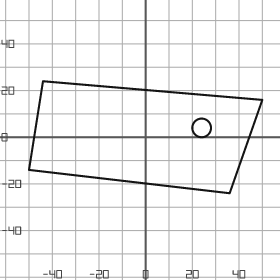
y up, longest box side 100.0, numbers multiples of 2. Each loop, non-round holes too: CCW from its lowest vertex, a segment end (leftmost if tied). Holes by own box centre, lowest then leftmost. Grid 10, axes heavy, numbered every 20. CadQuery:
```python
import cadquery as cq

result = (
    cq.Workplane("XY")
    .moveTo(36.0, -24.0)
    .lineTo(50.0, 16.0)
    .lineTo(-44.0, 24.0)
    .lineTo(-50.0, -14.0)
    .close()
    .moveTo(24.0, 4.0)
    .circle(4.0)
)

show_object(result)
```